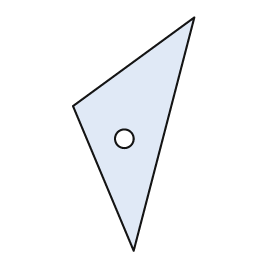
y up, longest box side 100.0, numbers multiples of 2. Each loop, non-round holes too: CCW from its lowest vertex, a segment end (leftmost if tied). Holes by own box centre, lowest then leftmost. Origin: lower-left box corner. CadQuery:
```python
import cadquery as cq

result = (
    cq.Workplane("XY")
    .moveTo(26.0, 0.0)
    .lineTo(52.0, 100.0)
    .lineTo(0.0, 62.0)
    .close()
    .moveTo(22.0, 48.0)
    .circle(4.0)
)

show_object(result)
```